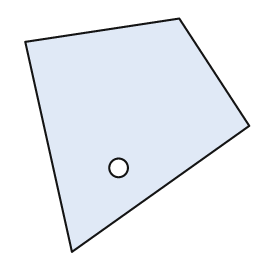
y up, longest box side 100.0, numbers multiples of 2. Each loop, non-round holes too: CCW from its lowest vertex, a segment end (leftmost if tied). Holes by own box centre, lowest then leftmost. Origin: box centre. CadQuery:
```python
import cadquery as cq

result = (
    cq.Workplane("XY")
    .moveTo(-28.0, -50.0)
    .lineTo(48.0, 4.0)
    .lineTo(18.0, 50.0)
    .lineTo(-48.0, 40.0)
    .close()
    .moveTo(-8.0, -14.0)
    .circle(4.0)
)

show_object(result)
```